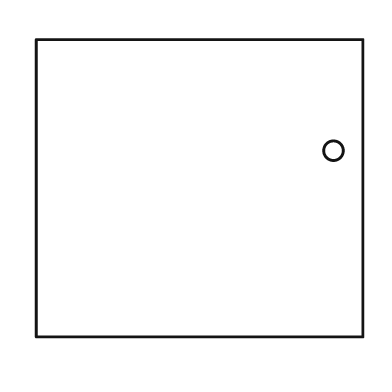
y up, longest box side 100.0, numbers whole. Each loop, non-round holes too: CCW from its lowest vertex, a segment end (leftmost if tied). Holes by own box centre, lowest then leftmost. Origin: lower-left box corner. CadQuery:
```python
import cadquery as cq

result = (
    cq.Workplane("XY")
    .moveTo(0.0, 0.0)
    .lineTo(100.0, 0.0)
    .lineTo(100.0, 91.0)
    .lineTo(0.0, 91.0)
    .close()
    .moveTo(91.0, 57.0)
    .circle(3.0)
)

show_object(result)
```